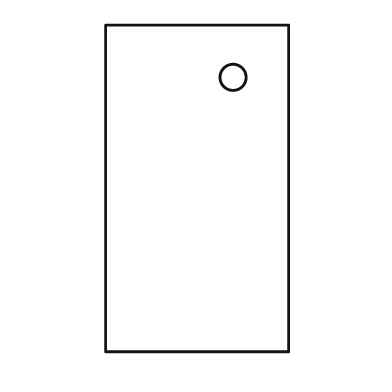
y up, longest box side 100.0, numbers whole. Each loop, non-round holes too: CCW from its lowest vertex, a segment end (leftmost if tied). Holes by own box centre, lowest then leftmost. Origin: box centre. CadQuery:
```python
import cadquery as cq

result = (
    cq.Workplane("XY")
    .moveTo(-28.0, -50.0)
    .lineTo(28.0, -50.0)
    .lineTo(28.0, 50.0)
    .lineTo(-28.0, 50.0)
    .close()
    .moveTo(11.0, 34.0)
    .circle(4.0)
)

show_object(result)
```